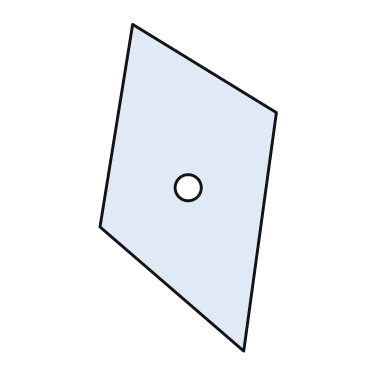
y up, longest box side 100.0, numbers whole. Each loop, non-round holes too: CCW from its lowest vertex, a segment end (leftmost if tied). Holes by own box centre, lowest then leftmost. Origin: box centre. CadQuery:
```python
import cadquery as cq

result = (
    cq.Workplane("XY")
    .moveTo(17.0, -50.0)
    .lineTo(27.0, 23.0)
    .lineTo(-17.0, 50.0)
    .lineTo(-27.0, -12.0)
    .close()
    .moveTo(0.0, 0.0)
    .circle(4.0)
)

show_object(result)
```